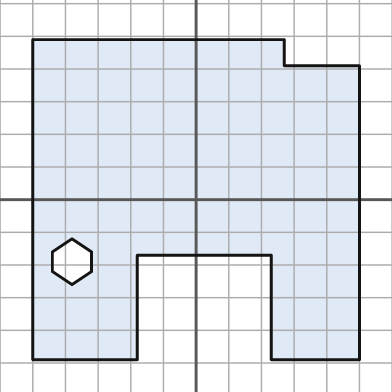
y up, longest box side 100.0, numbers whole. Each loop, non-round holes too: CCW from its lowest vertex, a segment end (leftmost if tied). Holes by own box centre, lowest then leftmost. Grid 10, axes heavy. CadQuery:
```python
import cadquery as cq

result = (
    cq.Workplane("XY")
    .moveTo(-50.0, -49.0)
    .lineTo(-18.0, -49.0)
    .lineTo(-18.0, -17.0)
    .lineTo(23.0, -17.0)
    .lineTo(23.0, -49.0)
    .lineTo(50.0, -49.0)
    .lineTo(50.0, 41.0)
    .lineTo(27.0, 41.0)
    .lineTo(27.0, 49.0)
    .lineTo(-50.0, 49.0)
    .close()
    .moveTo(-38.0, -26.0)
    .lineTo(-32.0, -22.0)
    .lineTo(-32.0, -16.0)
    .lineTo(-38.0, -12.0)
    .lineTo(-44.0, -16.0)
    .lineTo(-44.0, -22.0)
    .close()
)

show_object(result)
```